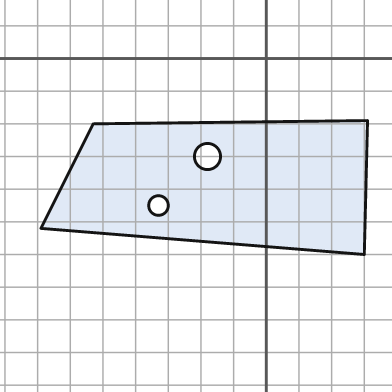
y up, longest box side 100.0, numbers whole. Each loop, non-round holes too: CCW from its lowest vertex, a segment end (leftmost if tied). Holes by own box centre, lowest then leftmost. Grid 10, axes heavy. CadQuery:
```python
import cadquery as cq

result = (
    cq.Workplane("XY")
    .moveTo(30.0, -60.0)
    .lineTo(31.0, -19.0)
    .lineTo(-53.0, -20.0)
    .lineTo(-69.0, -52.0)
    .close()
    .moveTo(-33.0, -45.0)
    .circle(3.0)
    .moveTo(-18.0, -30.0)
    .circle(4.0)
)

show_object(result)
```